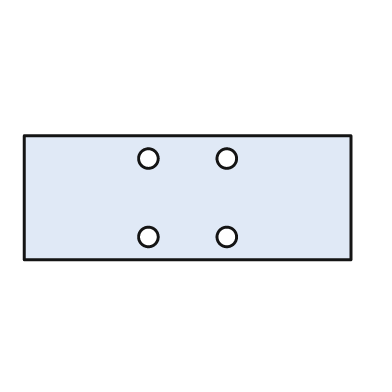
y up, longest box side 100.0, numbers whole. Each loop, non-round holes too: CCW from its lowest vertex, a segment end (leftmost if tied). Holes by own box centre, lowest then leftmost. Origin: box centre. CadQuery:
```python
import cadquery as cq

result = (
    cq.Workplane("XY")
    .moveTo(-50.0, -19.0)
    .lineTo(50.0, -19.0)
    .lineTo(50.0, 19.0)
    .lineTo(-50.0, 19.0)
    .close()
    .moveTo(-12.0, -12.0)
    .circle(3.0)
    .moveTo(12.0, -12.0)
    .circle(3.0)
    .moveTo(-12.0, 12.0)
    .circle(3.0)
    .moveTo(12.0, 12.0)
    .circle(3.0)
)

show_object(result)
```